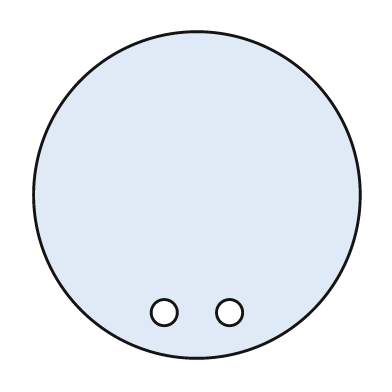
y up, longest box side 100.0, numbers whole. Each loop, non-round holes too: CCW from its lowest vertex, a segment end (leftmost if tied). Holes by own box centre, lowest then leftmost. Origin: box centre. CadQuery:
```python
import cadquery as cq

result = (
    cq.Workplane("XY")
    .moveTo(0.0, 0.0)
    .circle(50.0)
    .moveTo(-10.0, -36.0)
    .circle(4.0)
    .moveTo(10.0, -36.0)
    .circle(4.0)
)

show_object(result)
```